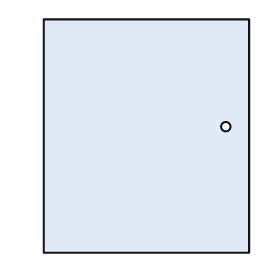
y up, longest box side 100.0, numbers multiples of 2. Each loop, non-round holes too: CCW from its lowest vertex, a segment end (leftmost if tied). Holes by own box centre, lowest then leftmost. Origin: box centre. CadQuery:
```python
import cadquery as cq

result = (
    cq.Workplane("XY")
    .moveTo(-44.0, -50.0)
    .lineTo(44.0, -50.0)
    .lineTo(44.0, 50.0)
    .lineTo(-44.0, 50.0)
    .close()
    .moveTo(34.0, 4.0)
    .circle(2.0)
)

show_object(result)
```